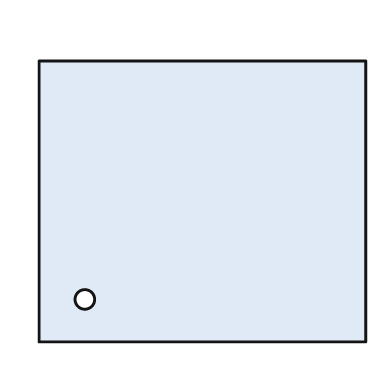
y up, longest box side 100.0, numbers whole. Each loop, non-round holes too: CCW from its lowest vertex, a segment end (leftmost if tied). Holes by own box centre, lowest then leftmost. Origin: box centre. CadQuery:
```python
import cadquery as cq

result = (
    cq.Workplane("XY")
    .moveTo(-50.0, -43.0)
    .lineTo(50.0, -43.0)
    .lineTo(50.0, 43.0)
    .lineTo(-50.0, 43.0)
    .close()
    .moveTo(-36.0, -30.0)
    .circle(3.0)
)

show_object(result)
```